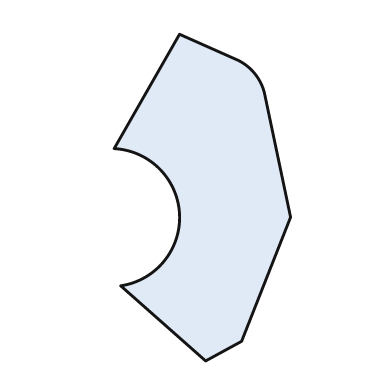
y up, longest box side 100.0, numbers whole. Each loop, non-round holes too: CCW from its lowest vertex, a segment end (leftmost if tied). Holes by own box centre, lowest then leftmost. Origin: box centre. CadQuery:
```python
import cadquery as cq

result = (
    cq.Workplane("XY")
    .moveTo(1.0, -50.0)
    .lineTo(12.0, -44.0)
    .lineTo(27.0, -6.0)
    .lineTo(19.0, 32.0)
    .threePointArc((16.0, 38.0), (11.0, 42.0))
    .lineTo(-7.0, 50.0)
    .lineTo(-27.0, 15.0)
    .threePointArc((-7.0, -5.0), (-25.0, -27.0))
    .close()
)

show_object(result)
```